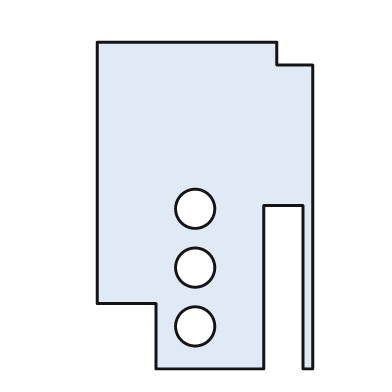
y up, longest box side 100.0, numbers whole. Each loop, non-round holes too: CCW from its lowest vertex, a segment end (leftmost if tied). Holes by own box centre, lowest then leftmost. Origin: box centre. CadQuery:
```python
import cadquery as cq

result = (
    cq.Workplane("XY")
    .moveTo(-15.0, -50.0)
    .lineTo(18.0, -50.0)
    .lineTo(18.0, 0.0)
    .lineTo(30.0, 0.0)
    .lineTo(30.0, -50.0)
    .lineTo(33.0, -50.0)
    .lineTo(33.0, 43.0)
    .lineTo(22.0, 43.0)
    .lineTo(22.0, 50.0)
    .lineTo(-33.0, 50.0)
    .lineTo(-33.0, -30.0)
    .lineTo(-15.0, -30.0)
    .close()
    .moveTo(-3.0, -37.0)
    .circle(6.0)
    .moveTo(-3.0, -19.0)
    .circle(6.0)
    .moveTo(-3.0, -1.0)
    .circle(6.0)
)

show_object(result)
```